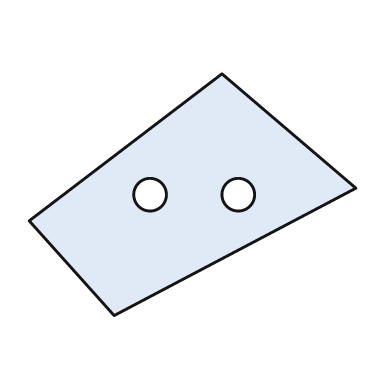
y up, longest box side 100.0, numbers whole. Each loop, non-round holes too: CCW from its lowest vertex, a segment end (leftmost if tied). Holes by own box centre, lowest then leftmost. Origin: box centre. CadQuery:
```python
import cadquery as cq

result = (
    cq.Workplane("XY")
    .moveTo(-24.0, -37.0)
    .lineTo(50.0, 2.0)
    .lineTo(9.0, 37.0)
    .lineTo(-50.0, -8.0)
    .close()
    .moveTo(-13.0, 0.0)
    .circle(5.0)
    .moveTo(14.0, 0.0)
    .circle(5.0)
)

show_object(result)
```